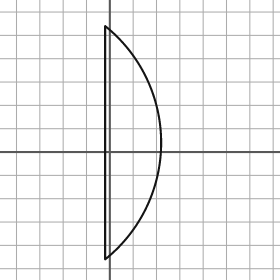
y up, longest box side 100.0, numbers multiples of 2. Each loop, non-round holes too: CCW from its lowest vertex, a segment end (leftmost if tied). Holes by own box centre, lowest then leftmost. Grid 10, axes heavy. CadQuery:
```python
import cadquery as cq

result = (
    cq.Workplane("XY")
    .moveTo(-2.0, -46.0)
    .threePointArc((22.0, 4.0), (-2.0, 54.0))
    .close()
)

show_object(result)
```